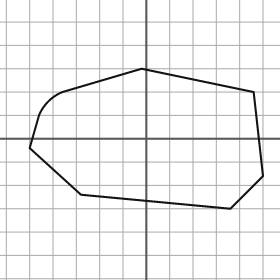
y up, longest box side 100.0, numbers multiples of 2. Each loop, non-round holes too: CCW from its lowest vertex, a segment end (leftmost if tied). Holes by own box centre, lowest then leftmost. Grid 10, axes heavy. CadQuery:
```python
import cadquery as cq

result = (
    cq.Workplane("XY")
    .moveTo(36.0, -30.0)
    .lineTo(50.0, -16.0)
    .lineTo(46.0, 20.0)
    .lineTo(-2.0, 30.0)
    .lineTo(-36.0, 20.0)
    .threePointArc((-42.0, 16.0), (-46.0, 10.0))
    .lineTo(-50.0, -4.0)
    .lineTo(-28.0, -24.0)
    .close()
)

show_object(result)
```